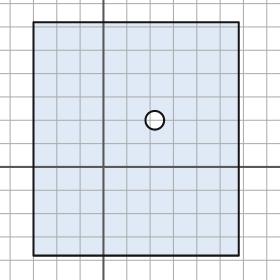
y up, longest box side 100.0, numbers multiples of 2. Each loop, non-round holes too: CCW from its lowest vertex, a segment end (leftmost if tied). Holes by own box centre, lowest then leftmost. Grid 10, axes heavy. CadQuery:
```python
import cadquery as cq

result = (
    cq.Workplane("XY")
    .moveTo(-30.0, -38.0)
    .lineTo(58.0, -38.0)
    .lineTo(58.0, 62.0)
    .lineTo(-30.0, 62.0)
    .close()
    .moveTo(22.0, 20.0)
    .circle(4.0)
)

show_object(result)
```